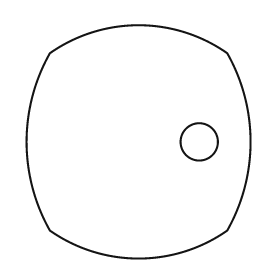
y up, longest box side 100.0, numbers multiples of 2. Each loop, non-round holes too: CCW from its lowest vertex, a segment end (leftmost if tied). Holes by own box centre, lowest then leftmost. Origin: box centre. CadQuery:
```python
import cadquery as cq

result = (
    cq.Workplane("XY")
    .moveTo(-38.0, -38.0)
    .threePointArc((0.0, -50.0), (38.0, -38.0))
    .threePointArc((48.0, 0.0), (38.0, 38.0))
    .threePointArc((0.0, 50.0), (-38.0, 38.0))
    .threePointArc((-48.0, 0.0), (-38.0, -38.0))
    .close()
    .moveTo(26.0, 0.0)
    .circle(8.0)
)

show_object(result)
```